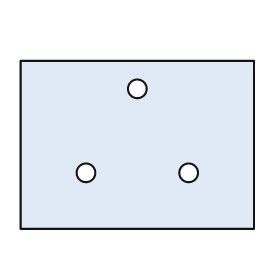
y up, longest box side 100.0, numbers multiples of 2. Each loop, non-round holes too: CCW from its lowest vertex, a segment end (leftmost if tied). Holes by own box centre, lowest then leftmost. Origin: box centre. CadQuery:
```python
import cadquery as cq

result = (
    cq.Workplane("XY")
    .moveTo(-50.0, -36.0)
    .lineTo(50.0, -36.0)
    .lineTo(50.0, 36.0)
    .lineTo(-50.0, 36.0)
    .close()
    .moveTo(-22.0, -12.0)
    .circle(4.0)
    .moveTo(22.0, -12.0)
    .circle(4.0)
    .moveTo(0.0, 24.0)
    .circle(4.0)
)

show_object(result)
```